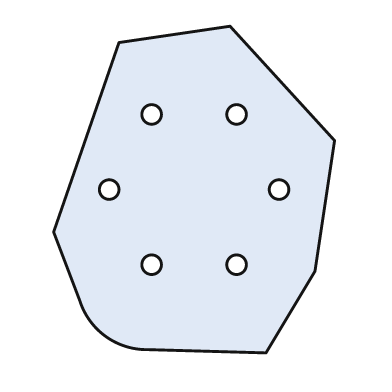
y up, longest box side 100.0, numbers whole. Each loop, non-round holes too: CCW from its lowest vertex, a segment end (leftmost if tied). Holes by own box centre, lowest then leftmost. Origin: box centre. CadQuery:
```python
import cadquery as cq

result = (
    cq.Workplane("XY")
    .moveTo(22.0, -50.0)
    .lineTo(37.0, -25.0)
    .lineTo(43.0, 15.0)
    .lineTo(11.0, 50.0)
    .lineTo(-23.0, 45.0)
    .lineTo(-43.0, -13.0)
    .lineTo(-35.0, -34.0)
    .threePointArc((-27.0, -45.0), (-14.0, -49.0))
    .close()
    .moveTo(-13.0, -23.0)
    .circle(3.0)
    .moveTo(13.0, -23.0)
    .circle(3.0)
    .moveTo(-26.0, 0.0)
    .circle(3.0)
    .moveTo(26.0, 0.0)
    .circle(3.0)
    .moveTo(-13.0, 23.0)
    .circle(3.0)
    .moveTo(13.0, 23.0)
    .circle(3.0)
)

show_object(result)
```